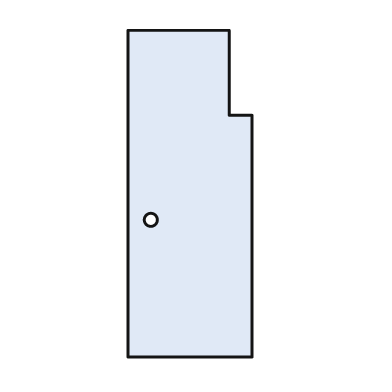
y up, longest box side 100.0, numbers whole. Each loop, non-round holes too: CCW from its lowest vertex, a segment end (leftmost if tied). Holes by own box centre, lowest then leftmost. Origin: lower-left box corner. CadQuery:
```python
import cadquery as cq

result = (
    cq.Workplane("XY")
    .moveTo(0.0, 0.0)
    .lineTo(38.0, 0.0)
    .lineTo(38.0, 74.0)
    .lineTo(31.0, 74.0)
    .lineTo(31.0, 100.0)
    .lineTo(0.0, 100.0)
    .close()
    .moveTo(7.0, 42.0)
    .circle(2.0)
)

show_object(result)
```